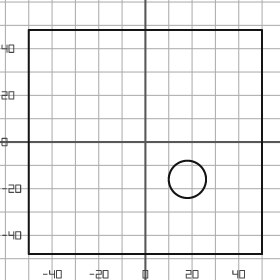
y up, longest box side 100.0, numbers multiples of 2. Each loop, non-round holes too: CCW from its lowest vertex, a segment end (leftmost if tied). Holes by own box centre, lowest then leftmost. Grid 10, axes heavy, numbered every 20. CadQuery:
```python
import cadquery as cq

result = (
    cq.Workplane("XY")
    .moveTo(-50.0, -48.0)
    .lineTo(50.0, -48.0)
    .lineTo(50.0, 48.0)
    .lineTo(-50.0, 48.0)
    .close()
    .moveTo(18.0, -16.0)
    .circle(8.0)
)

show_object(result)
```